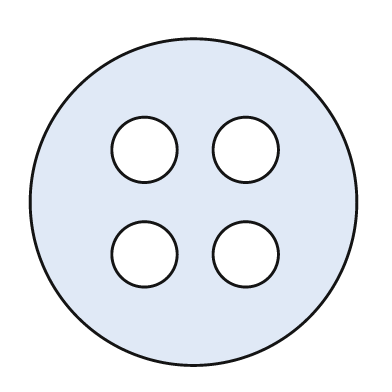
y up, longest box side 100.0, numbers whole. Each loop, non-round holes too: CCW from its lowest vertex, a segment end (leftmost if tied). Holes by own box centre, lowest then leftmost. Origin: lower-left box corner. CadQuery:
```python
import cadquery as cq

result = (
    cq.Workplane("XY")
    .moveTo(50.0, 50.0)
    .circle(50.0)
    .moveTo(35.0, 34.0)
    .circle(10.0)
    .moveTo(66.0, 34.0)
    .circle(10.0)
    .moveTo(35.0, 66.0)
    .circle(10.0)
    .moveTo(66.0, 66.0)
    .circle(10.0)
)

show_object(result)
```